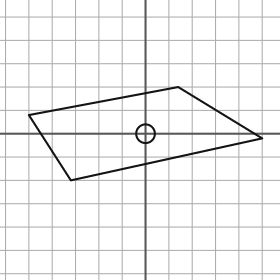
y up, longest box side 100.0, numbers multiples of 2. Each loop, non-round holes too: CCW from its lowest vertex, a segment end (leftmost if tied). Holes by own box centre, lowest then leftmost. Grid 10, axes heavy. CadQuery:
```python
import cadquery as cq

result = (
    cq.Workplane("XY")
    .moveTo(-32.0, -20.0)
    .lineTo(50.0, -2.0)
    .lineTo(14.0, 20.0)
    .lineTo(-50.0, 8.0)
    .close()
    .moveTo(0.0, 0.0)
    .circle(4.0)
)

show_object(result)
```